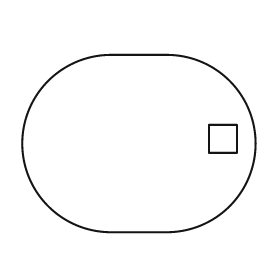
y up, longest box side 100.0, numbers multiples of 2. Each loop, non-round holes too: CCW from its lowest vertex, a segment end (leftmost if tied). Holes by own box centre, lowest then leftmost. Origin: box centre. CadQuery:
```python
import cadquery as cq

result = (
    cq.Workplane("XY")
    .moveTo(-12.0, -38.0)
    .lineTo(12.0, -38.0)
    .threePointArc((50.0, 0.0), (12.0, 38.0))
    .lineTo(-12.0, 38.0)
    .threePointArc((-50.0, 0.0), (-12.0, -38.0))
    .close()
    .moveTo(30.0, -4.0)
    .lineTo(42.0, -4.0)
    .lineTo(42.0, 8.0)
    .lineTo(30.0, 8.0)
    .close()
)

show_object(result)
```